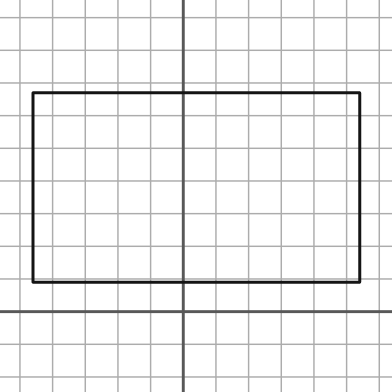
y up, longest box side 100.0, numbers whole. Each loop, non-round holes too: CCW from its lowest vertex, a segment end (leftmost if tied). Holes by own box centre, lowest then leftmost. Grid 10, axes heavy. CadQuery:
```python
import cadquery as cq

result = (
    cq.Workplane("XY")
    .moveTo(-46.0, 9.0)
    .lineTo(54.0, 9.0)
    .lineTo(54.0, 67.0)
    .lineTo(-46.0, 67.0)
    .close()
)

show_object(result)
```